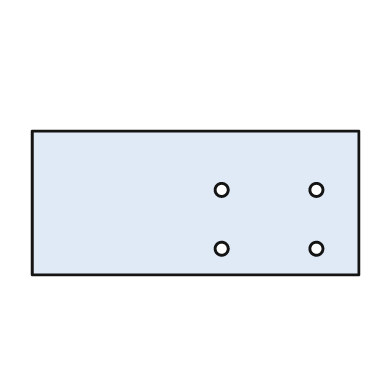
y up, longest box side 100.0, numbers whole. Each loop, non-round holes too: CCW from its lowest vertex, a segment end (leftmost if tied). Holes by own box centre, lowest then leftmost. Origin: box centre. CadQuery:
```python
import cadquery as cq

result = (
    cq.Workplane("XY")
    .moveTo(-50.0, -22.0)
    .lineTo(50.0, -22.0)
    .lineTo(50.0, 22.0)
    .lineTo(-50.0, 22.0)
    .close()
    .moveTo(8.0, -14.0)
    .circle(2.0)
    .moveTo(37.0, -14.0)
    .circle(2.0)
    .moveTo(8.0, 4.0)
    .circle(2.0)
    .moveTo(37.0, 4.0)
    .circle(2.0)
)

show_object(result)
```